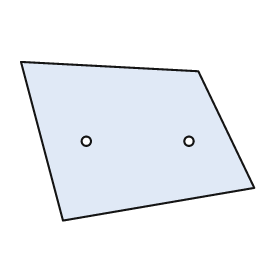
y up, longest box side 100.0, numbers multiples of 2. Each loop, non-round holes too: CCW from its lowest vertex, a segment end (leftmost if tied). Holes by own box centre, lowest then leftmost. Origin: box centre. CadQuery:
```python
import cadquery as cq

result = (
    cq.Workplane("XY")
    .moveTo(-32.0, -34.0)
    .lineTo(50.0, -20.0)
    .lineTo(26.0, 30.0)
    .lineTo(-50.0, 34.0)
    .close()
    .moveTo(-22.0, 0.0)
    .circle(2.0)
    .moveTo(22.0, 0.0)
    .circle(2.0)
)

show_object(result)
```